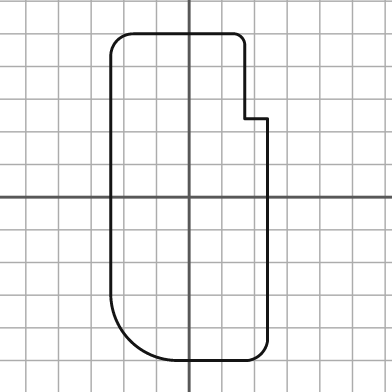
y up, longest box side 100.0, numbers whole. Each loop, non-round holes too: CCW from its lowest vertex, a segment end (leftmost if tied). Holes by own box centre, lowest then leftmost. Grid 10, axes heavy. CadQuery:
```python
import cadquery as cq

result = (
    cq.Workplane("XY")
    .moveTo(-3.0, -50.0)
    .lineTo(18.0, -50.0)
    .threePointArc((22.0, -48.0), (24.0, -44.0))
    .lineTo(24.0, 24.0)
    .lineTo(17.0, 24.0)
    .lineTo(17.0, 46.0)
    .threePointArc((16.0, 49.0), (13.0, 50.0))
    .lineTo(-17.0, 50.0)
    .threePointArc((-22.0, 48.0), (-24.0, 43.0))
    .lineTo(-24.0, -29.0)
    .threePointArc((-18.0, -44.0), (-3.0, -50.0))
    .close()
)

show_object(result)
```